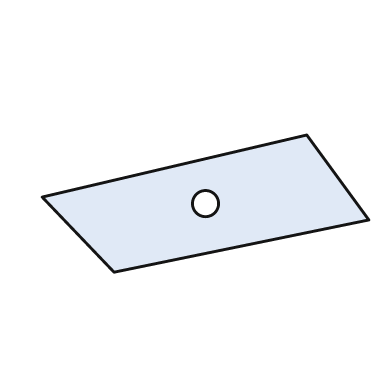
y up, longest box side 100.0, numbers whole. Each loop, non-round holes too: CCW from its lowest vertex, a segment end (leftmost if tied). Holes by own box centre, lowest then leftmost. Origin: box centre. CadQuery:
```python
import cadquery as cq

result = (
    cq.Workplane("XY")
    .moveTo(-28.0, -21.0)
    .lineTo(50.0, -5.0)
    .lineTo(31.0, 21.0)
    .lineTo(-50.0, 2.0)
    .close()
    .moveTo(0.0, 0.0)
    .circle(4.0)
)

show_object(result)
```